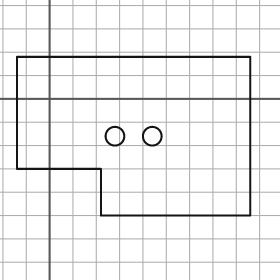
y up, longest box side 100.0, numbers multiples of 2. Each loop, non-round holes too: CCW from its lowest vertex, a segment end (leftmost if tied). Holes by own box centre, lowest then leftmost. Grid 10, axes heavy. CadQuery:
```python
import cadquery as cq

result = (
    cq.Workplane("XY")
    .moveTo(22.0, -50.0)
    .lineTo(86.0, -50.0)
    .lineTo(86.0, 18.0)
    .lineTo(-14.0, 18.0)
    .lineTo(-14.0, -30.0)
    .lineTo(22.0, -30.0)
    .close()
    .moveTo(28.0, -16.0)
    .circle(4.0)
    .moveTo(44.0, -16.0)
    .circle(4.0)
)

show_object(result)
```